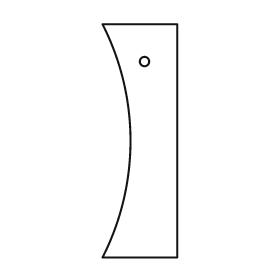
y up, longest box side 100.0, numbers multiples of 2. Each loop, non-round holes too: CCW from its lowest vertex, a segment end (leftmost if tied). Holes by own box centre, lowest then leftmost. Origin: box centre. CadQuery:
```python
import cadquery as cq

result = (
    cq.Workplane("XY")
    .moveTo(-16.0, -50.0)
    .lineTo(16.0, -50.0)
    .lineTo(16.0, 50.0)
    .lineTo(-16.0, 50.0)
    .threePointArc((-4.0, 0.0), (-16.0, -50.0))
    .close()
    .moveTo(2.0, 34.0)
    .circle(2.0)
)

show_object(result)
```